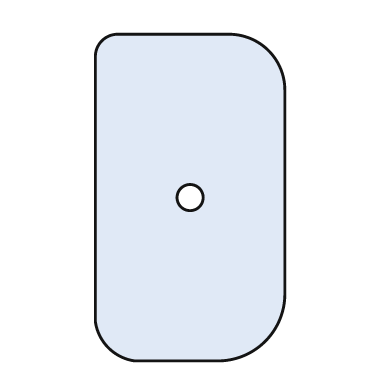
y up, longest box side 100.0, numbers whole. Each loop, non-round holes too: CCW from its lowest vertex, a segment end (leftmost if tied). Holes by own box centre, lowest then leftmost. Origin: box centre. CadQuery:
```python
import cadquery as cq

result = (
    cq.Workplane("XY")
    .moveTo(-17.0, -50.0)
    .lineTo(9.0, -50.0)
    .threePointArc((23.0, -44.0), (29.0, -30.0))
    .lineTo(29.0, 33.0)
    .threePointArc((24.0, 45.0), (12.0, 50.0))
    .lineTo(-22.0, 50.0)
    .threePointArc((-27.0, 48.0), (-29.0, 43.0))
    .lineTo(-29.0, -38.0)
    .threePointArc((-25.0, -46.0), (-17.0, -50.0))
    .close()
    .moveTo(0.0, 0.0)
    .circle(4.0)
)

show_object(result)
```